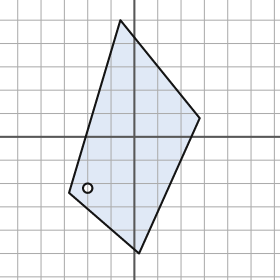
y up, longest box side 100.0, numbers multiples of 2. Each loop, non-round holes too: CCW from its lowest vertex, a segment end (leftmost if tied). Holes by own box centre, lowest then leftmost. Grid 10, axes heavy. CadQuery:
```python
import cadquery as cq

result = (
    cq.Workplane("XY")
    .moveTo(2.0, -50.0)
    .lineTo(28.0, 8.0)
    .lineTo(-6.0, 50.0)
    .lineTo(-28.0, -24.0)
    .close()
    .moveTo(-20.0, -22.0)
    .circle(2.0)
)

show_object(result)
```